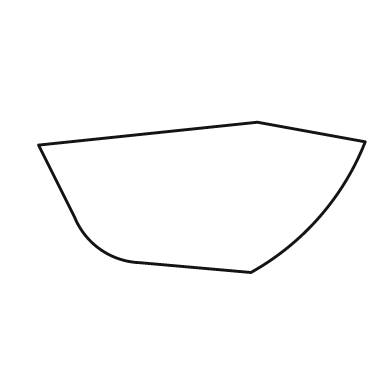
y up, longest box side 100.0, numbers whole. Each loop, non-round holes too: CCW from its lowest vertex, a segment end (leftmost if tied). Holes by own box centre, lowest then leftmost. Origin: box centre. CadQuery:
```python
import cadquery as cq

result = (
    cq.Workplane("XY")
    .moveTo(15.0, -23.0)
    .threePointArc((36.0, -6.0), (50.0, 17.0))
    .lineTo(17.0, 23.0)
    .lineTo(-50.0, 16.0)
    .lineTo(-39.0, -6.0)
    .threePointArc((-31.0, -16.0), (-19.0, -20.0))
    .close()
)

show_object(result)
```